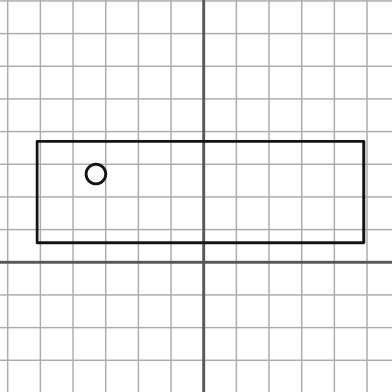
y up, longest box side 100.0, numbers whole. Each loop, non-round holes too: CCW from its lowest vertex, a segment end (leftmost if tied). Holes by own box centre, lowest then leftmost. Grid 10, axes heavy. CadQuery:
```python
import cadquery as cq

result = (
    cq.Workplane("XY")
    .moveTo(-51.0, 6.0)
    .lineTo(49.0, 6.0)
    .lineTo(49.0, 37.0)
    .lineTo(-51.0, 37.0)
    .close()
    .moveTo(-33.0, 27.0)
    .circle(3.0)
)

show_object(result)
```